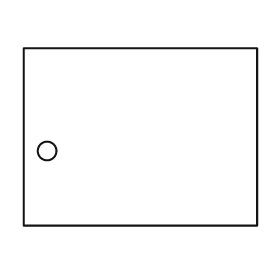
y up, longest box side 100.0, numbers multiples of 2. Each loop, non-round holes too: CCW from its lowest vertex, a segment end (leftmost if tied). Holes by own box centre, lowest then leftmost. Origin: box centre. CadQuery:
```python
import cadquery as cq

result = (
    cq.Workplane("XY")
    .moveTo(-50.0, -38.0)
    .lineTo(50.0, -38.0)
    .lineTo(50.0, 38.0)
    .lineTo(-50.0, 38.0)
    .close()
    .moveTo(-40.0, -6.0)
    .circle(4.0)
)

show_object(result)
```